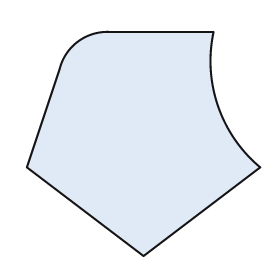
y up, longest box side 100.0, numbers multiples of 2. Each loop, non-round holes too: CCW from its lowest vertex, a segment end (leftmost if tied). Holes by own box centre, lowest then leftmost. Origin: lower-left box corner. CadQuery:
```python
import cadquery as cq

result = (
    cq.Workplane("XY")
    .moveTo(50.0, 0.0)
    .lineTo(100.0, 38.0)
    .threePointArc((82.0, 64.0), (80.0, 96.0))
    .lineTo(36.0, 96.0)
    .threePointArc((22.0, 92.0), (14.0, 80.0))
    .lineTo(0.0, 38.0)
    .close()
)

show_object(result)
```